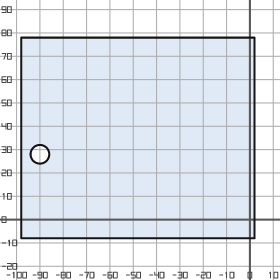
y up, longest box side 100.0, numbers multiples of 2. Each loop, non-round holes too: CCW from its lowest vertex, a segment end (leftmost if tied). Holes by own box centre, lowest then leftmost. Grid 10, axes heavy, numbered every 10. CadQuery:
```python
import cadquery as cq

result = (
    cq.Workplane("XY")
    .moveTo(-98.0, -8.0)
    .lineTo(2.0, -8.0)
    .lineTo(2.0, 78.0)
    .lineTo(-98.0, 78.0)
    .close()
    .moveTo(-90.0, 28.0)
    .circle(4.0)
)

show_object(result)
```